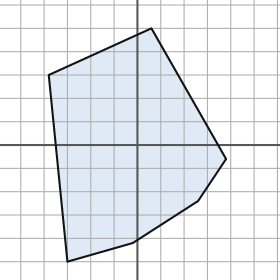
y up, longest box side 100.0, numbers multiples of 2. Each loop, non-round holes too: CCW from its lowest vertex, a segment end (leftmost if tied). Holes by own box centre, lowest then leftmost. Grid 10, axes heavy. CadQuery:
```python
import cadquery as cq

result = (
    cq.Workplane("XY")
    .moveTo(-30.0, -50.0)
    .lineTo(-2.0, -42.0)
    .lineTo(26.0, -24.0)
    .lineTo(38.0, -6.0)
    .lineTo(6.0, 50.0)
    .lineTo(-38.0, 30.0)
    .close()
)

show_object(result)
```